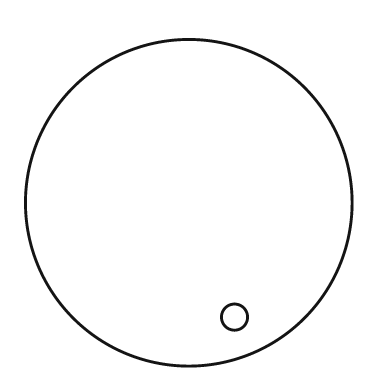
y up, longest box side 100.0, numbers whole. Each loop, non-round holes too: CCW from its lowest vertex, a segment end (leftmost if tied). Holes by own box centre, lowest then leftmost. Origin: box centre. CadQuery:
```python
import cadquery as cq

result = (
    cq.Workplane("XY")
    .moveTo(0.0, 0.0)
    .circle(50.0)
    .moveTo(14.0, -35.0)
    .circle(4.0)
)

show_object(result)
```